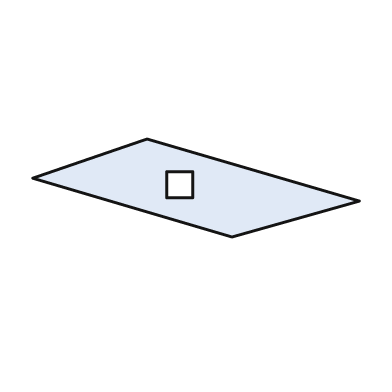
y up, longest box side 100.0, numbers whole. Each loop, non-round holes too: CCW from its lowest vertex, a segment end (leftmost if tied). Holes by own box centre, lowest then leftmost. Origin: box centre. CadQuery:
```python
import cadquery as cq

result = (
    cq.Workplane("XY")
    .moveTo(11.0, -15.0)
    .lineTo(50.0, -4.0)
    .lineTo(-15.0, 15.0)
    .lineTo(-50.0, 3.0)
    .close()
    .moveTo(-9.0, -3.0)
    .lineTo(-1.0, -3.0)
    .lineTo(-1.0, 5.0)
    .lineTo(-9.0, 5.0)
    .close()
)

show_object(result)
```